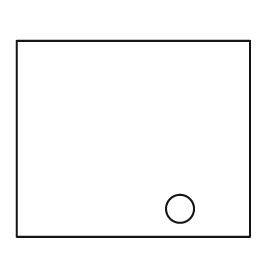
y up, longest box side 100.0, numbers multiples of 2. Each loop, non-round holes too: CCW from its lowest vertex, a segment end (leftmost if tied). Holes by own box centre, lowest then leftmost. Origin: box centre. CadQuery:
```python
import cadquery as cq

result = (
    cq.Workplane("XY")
    .moveTo(-50.0, -42.0)
    .lineTo(50.0, -42.0)
    .lineTo(50.0, 42.0)
    .lineTo(-50.0, 42.0)
    .close()
    .moveTo(20.0, -30.0)
    .circle(6.0)
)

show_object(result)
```